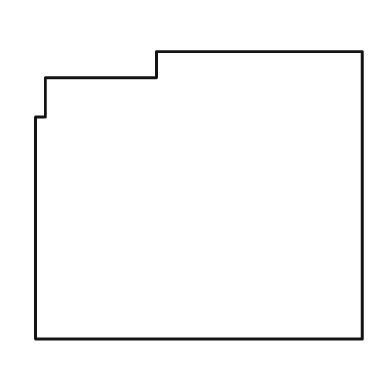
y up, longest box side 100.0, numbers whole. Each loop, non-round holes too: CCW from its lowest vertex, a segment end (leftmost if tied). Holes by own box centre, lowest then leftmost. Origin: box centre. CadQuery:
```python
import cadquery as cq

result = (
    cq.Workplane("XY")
    .moveTo(-50.0, -44.0)
    .lineTo(50.0, -44.0)
    .lineTo(50.0, 44.0)
    .lineTo(-13.0, 44.0)
    .lineTo(-13.0, 36.0)
    .lineTo(-47.0, 36.0)
    .lineTo(-47.0, 24.0)
    .lineTo(-50.0, 24.0)
    .close()
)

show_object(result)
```